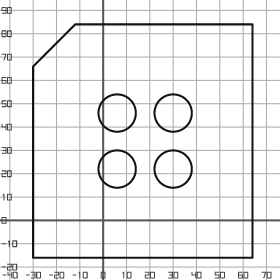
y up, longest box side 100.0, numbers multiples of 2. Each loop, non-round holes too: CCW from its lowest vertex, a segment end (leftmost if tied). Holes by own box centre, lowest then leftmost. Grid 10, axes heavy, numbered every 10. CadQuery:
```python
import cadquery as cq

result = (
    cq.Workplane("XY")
    .moveTo(-30.0, -16.0)
    .lineTo(64.0, -16.0)
    .lineTo(64.0, 84.0)
    .lineTo(-12.0, 84.0)
    .lineTo(-30.0, 66.0)
    .close()
    .moveTo(6.0, 22.0)
    .circle(8.0)
    .moveTo(30.0, 22.0)
    .circle(8.0)
    .moveTo(6.0, 46.0)
    .circle(8.0)
    .moveTo(30.0, 46.0)
    .circle(8.0)
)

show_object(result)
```